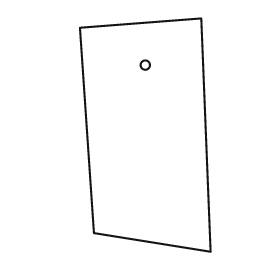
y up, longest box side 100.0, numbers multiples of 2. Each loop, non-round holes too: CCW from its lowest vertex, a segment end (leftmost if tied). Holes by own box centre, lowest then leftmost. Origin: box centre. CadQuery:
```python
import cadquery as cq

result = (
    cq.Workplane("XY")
    .moveTo(28.0, -50.0)
    .lineTo(24.0, 50.0)
    .lineTo(-28.0, 46.0)
    .lineTo(-22.0, -42.0)
    .close()
    .moveTo(0.0, 30.0)
    .circle(2.0)
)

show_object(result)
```